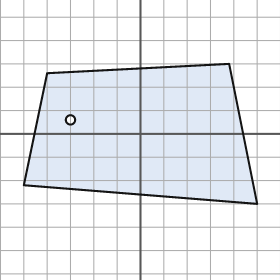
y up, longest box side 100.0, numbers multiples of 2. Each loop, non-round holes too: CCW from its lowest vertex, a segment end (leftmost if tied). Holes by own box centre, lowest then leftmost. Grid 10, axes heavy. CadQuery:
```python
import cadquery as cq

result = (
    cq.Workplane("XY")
    .moveTo(50.0, -30.0)
    .lineTo(38.0, 30.0)
    .lineTo(-40.0, 26.0)
    .lineTo(-50.0, -22.0)
    .close()
    .moveTo(-30.0, 6.0)
    .circle(2.0)
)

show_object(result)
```